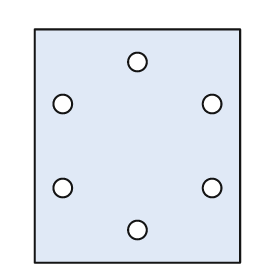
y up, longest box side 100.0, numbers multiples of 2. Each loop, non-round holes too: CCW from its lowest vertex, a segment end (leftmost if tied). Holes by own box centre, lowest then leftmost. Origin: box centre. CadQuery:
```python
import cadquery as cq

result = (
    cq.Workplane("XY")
    .moveTo(-44.0, -50.0)
    .lineTo(44.0, -50.0)
    .lineTo(44.0, 50.0)
    .lineTo(-44.0, 50.0)
    .close()
    .moveTo(0.0, -36.0)
    .circle(4.0)
    .moveTo(-32.0, -18.0)
    .circle(4.0)
    .moveTo(32.0, -18.0)
    .circle(4.0)
    .moveTo(-32.0, 18.0)
    .circle(4.0)
    .moveTo(32.0, 18.0)
    .circle(4.0)
    .moveTo(0.0, 36.0)
    .circle(4.0)
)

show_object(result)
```